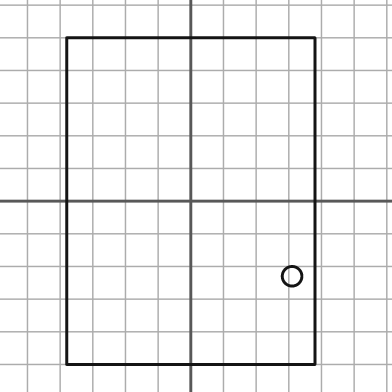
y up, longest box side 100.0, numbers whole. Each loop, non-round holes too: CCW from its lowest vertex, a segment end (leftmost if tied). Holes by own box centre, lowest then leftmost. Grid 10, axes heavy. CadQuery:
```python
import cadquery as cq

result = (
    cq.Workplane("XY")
    .moveTo(-38.0, -50.0)
    .lineTo(38.0, -50.0)
    .lineTo(38.0, 50.0)
    .lineTo(-38.0, 50.0)
    .close()
    .moveTo(31.0, -23.0)
    .circle(3.0)
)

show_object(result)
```